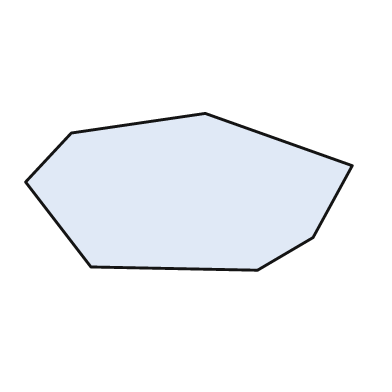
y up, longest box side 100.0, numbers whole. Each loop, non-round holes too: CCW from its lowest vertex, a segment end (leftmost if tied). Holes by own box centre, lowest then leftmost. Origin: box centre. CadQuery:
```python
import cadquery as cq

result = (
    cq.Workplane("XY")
    .moveTo(21.0, -24.0)
    .lineTo(38.0, -14.0)
    .lineTo(50.0, 8.0)
    .lineTo(5.0, 24.0)
    .lineTo(-36.0, 18.0)
    .lineTo(-50.0, 3.0)
    .lineTo(-30.0, -23.0)
    .close()
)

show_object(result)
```